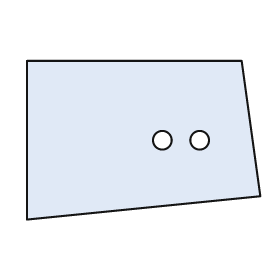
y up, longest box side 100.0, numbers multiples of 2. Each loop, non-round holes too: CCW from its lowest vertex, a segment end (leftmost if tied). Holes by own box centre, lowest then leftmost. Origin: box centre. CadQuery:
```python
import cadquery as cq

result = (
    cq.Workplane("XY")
    .moveTo(-50.0, -34.0)
    .lineTo(50.0, -24.0)
    .lineTo(42.0, 34.0)
    .lineTo(-50.0, 34.0)
    .close()
    .moveTo(8.0, 0.0)
    .circle(4.0)
    .moveTo(24.0, 0.0)
    .circle(4.0)
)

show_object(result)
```